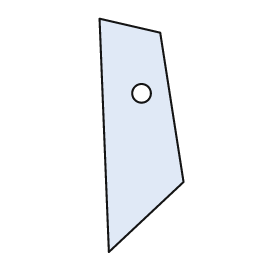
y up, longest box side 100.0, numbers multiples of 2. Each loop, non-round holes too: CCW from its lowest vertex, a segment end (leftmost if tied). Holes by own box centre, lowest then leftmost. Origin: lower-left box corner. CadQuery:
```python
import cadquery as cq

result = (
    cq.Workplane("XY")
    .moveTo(4.0, 0.0)
    .lineTo(36.0, 30.0)
    .lineTo(26.0, 94.0)
    .lineTo(0.0, 100.0)
    .close()
    .moveTo(18.0, 68.0)
    .circle(4.0)
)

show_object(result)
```